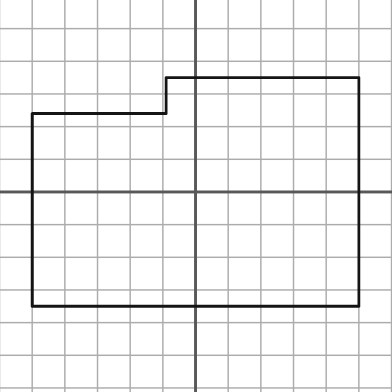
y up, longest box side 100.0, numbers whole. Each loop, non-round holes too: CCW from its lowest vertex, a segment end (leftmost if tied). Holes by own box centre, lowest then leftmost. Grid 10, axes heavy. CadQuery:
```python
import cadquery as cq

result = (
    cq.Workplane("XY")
    .moveTo(-50.0, -35.0)
    .lineTo(50.0, -35.0)
    .lineTo(50.0, 35.0)
    .lineTo(-9.0, 35.0)
    .lineTo(-9.0, 24.0)
    .lineTo(-50.0, 24.0)
    .close()
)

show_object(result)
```